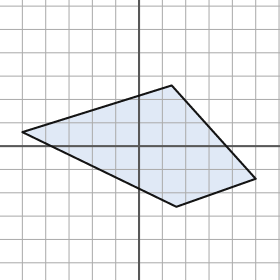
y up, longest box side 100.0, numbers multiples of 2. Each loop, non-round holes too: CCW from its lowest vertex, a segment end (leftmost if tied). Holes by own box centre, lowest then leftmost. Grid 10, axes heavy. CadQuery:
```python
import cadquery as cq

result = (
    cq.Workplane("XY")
    .moveTo(16.0, -26.0)
    .lineTo(50.0, -14.0)
    .lineTo(14.0, 26.0)
    .lineTo(-50.0, 6.0)
    .close()
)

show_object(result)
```